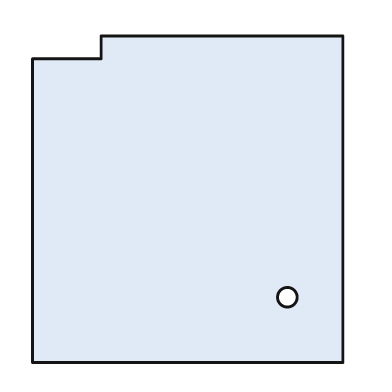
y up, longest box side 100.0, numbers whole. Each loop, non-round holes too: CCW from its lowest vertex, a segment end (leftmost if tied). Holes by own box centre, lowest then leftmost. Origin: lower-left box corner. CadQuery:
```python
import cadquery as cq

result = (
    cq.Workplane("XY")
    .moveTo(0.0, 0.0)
    .lineTo(95.0, 0.0)
    .lineTo(95.0, 100.0)
    .lineTo(21.0, 100.0)
    .lineTo(21.0, 93.0)
    .lineTo(0.0, 93.0)
    .close()
    .moveTo(78.0, 20.0)
    .circle(3.0)
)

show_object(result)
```